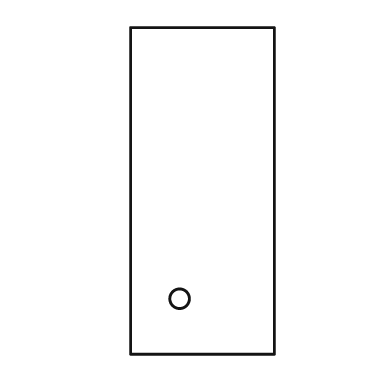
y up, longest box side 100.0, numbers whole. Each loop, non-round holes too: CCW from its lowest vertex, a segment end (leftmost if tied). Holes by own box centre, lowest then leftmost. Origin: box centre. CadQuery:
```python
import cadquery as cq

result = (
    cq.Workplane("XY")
    .moveTo(-22.0, -50.0)
    .lineTo(22.0, -50.0)
    .lineTo(22.0, 50.0)
    .lineTo(-22.0, 50.0)
    .close()
    .moveTo(-7.0, -33.0)
    .circle(3.0)
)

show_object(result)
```